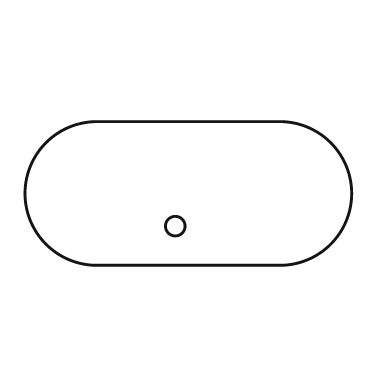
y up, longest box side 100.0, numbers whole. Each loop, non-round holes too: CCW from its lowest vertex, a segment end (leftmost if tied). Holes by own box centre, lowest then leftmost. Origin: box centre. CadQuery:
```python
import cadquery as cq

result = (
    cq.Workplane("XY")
    .moveTo(-28.0, -22.0)
    .lineTo(28.0, -22.0)
    .threePointArc((50.0, 0.0), (28.0, 22.0))
    .lineTo(-28.0, 22.0)
    .threePointArc((-50.0, 0.0), (-28.0, -22.0))
    .close()
    .moveTo(-4.0, -10.0)
    .circle(3.0)
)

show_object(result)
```